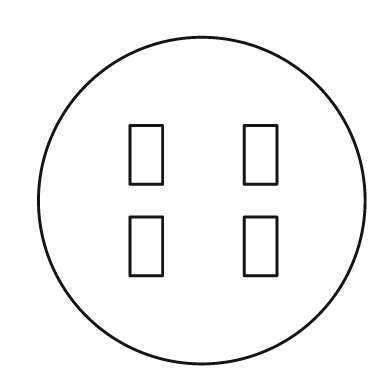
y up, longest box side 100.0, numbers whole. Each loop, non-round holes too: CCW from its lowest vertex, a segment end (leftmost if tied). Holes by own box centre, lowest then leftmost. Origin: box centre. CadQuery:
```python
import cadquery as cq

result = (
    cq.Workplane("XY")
    .moveTo(0.0, 0.0)
    .circle(50.0)
    .moveTo(-22.0, -23.0)
    .lineTo(-12.0, -23.0)
    .lineTo(-12.0, -5.0)
    .lineTo(-22.0, -5.0)
    .close()
    .moveTo(13.0, -23.0)
    .lineTo(23.0, -23.0)
    .lineTo(23.0, -5.0)
    .lineTo(13.0, -5.0)
    .close()
    .moveTo(-22.0, 5.0)
    .lineTo(-12.0, 5.0)
    .lineTo(-12.0, 23.0)
    .lineTo(-22.0, 23.0)
    .close()
    .moveTo(13.0, 5.0)
    .lineTo(23.0, 5.0)
    .lineTo(23.0, 23.0)
    .lineTo(13.0, 23.0)
    .close()
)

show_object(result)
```